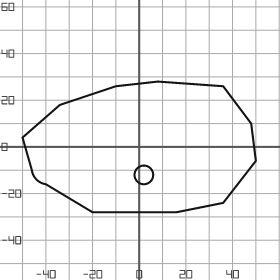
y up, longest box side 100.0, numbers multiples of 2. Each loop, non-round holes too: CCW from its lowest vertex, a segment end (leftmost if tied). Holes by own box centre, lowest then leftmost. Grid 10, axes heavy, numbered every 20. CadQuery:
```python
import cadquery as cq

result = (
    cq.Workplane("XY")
    .moveTo(-20.0, -28.0)
    .lineTo(16.0, -28.0)
    .lineTo(36.0, -24.0)
    .lineTo(50.0, -6.0)
    .lineTo(48.0, 10.0)
    .lineTo(36.0, 26.0)
    .lineTo(8.0, 28.0)
    .lineTo(-10.0, 26.0)
    .lineTo(-34.0, 18.0)
    .lineTo(-50.0, 4.0)
    .lineTo(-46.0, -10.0)
    .threePointArc((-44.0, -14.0), (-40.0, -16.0))
    .close()
    .moveTo(2.0, -12.0)
    .circle(4.0)
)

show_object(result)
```